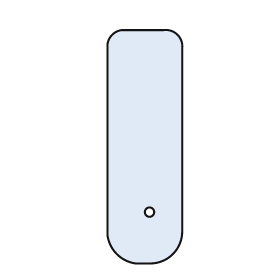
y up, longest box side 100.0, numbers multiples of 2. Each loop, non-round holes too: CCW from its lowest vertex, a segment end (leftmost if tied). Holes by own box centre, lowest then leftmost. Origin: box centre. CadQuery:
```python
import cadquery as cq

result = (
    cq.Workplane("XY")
    .moveTo(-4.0, -50.0)
    .lineTo(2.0, -50.0)
    .threePointArc((12.0, -46.0), (16.0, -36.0))
    .lineTo(16.0, 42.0)
    .threePointArc((14.0, 48.0), (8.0, 50.0))
    .lineTo(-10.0, 50.0)
    .threePointArc((-14.0, 48.0), (-16.0, 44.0))
    .lineTo(-16.0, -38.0)
    .threePointArc((-12.0, -46.0), (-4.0, -50.0))
    .close()
    .moveTo(2.0, -28.0)
    .circle(2.0)
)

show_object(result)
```